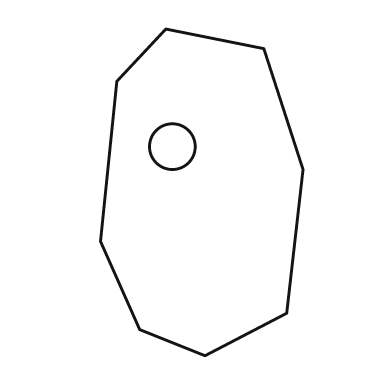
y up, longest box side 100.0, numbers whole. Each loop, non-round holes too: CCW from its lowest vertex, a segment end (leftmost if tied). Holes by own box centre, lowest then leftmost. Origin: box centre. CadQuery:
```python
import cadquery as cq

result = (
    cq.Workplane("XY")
    .moveTo(1.0, -50.0)
    .lineTo(26.0, -37.0)
    .lineTo(31.0, 7.0)
    .lineTo(19.0, 44.0)
    .lineTo(-11.0, 50.0)
    .lineTo(-26.0, 34.0)
    .lineTo(-31.0, -15.0)
    .lineTo(-19.0, -42.0)
    .close()
    .moveTo(-9.0, 14.0)
    .circle(7.0)
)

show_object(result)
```